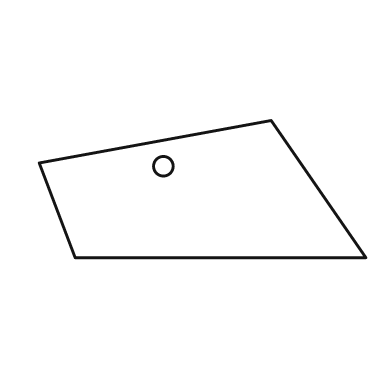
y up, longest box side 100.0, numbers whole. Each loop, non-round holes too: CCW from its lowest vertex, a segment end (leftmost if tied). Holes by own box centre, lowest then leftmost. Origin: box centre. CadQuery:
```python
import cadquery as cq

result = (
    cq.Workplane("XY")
    .moveTo(-39.0, -21.0)
    .lineTo(50.0, -21.0)
    .lineTo(21.0, 21.0)
    .lineTo(-50.0, 8.0)
    .close()
    .moveTo(-12.0, 7.0)
    .circle(3.0)
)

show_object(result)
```